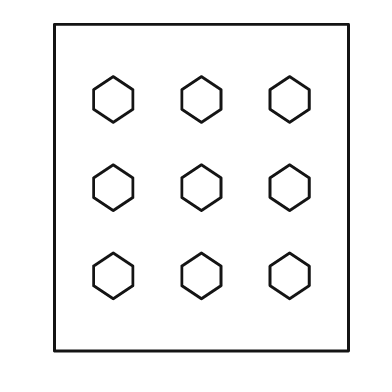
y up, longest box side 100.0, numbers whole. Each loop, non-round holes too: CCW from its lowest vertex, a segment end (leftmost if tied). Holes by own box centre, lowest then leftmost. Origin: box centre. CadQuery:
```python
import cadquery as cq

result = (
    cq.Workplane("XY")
    .moveTo(-45.0, -50.0)
    .lineTo(45.0, -50.0)
    .lineTo(45.0, 50.0)
    .lineTo(-45.0, 50.0)
    .close()
    .moveTo(-27.0, -34.0)
    .lineTo(-21.0, -30.0)
    .lineTo(-21.0, -24.0)
    .lineTo(-27.0, -20.0)
    .lineTo(-33.0, -24.0)
    .lineTo(-33.0, -30.0)
    .close()
    .moveTo(0.0, -34.0)
    .lineTo(6.0, -30.0)
    .lineTo(6.0, -24.0)
    .lineTo(0.0, -20.0)
    .lineTo(-6.0, -24.0)
    .lineTo(-6.0, -30.0)
    .close()
    .moveTo(27.0, -34.0)
    .lineTo(33.0, -30.0)
    .lineTo(33.0, -24.0)
    .lineTo(27.0, -20.0)
    .lineTo(21.0, -24.0)
    .lineTo(21.0, -30.0)
    .close()
    .moveTo(-27.0, -7.0)
    .lineTo(-21.0, -3.0)
    .lineTo(-21.0, 3.0)
    .lineTo(-27.0, 7.0)
    .lineTo(-33.0, 3.0)
    .lineTo(-33.0, -3.0)
    .close()
    .moveTo(0.0, -7.0)
    .lineTo(6.0, -3.0)
    .lineTo(6.0, 3.0)
    .lineTo(0.0, 7.0)
    .lineTo(-6.0, 3.0)
    .lineTo(-6.0, -3.0)
    .close()
    .moveTo(27.0, -7.0)
    .lineTo(33.0, -3.0)
    .lineTo(33.0, 3.0)
    .lineTo(27.0, 7.0)
    .lineTo(21.0, 3.0)
    .lineTo(21.0, -3.0)
    .close()
    .moveTo(-27.0, 20.0)
    .lineTo(-21.0, 24.0)
    .lineTo(-21.0, 30.0)
    .lineTo(-27.0, 34.0)
    .lineTo(-33.0, 30.0)
    .lineTo(-33.0, 24.0)
    .close()
    .moveTo(0.0, 20.0)
    .lineTo(6.0, 24.0)
    .lineTo(6.0, 30.0)
    .lineTo(0.0, 34.0)
    .lineTo(-6.0, 30.0)
    .lineTo(-6.0, 24.0)
    .close()
    .moveTo(27.0, 20.0)
    .lineTo(33.0, 24.0)
    .lineTo(33.0, 30.0)
    .lineTo(27.0, 34.0)
    .lineTo(21.0, 30.0)
    .lineTo(21.0, 24.0)
    .close()
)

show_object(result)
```